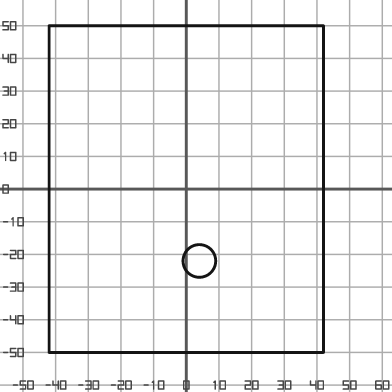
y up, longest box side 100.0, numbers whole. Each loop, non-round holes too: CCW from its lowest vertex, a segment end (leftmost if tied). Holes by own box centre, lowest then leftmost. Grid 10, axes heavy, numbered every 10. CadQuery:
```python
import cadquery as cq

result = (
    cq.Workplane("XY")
    .moveTo(-42.0, -50.0)
    .lineTo(42.0, -50.0)
    .lineTo(42.0, 50.0)
    .lineTo(-42.0, 50.0)
    .close()
    .moveTo(4.0, -22.0)
    .circle(5.0)
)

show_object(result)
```